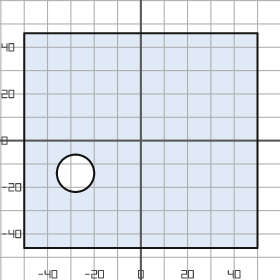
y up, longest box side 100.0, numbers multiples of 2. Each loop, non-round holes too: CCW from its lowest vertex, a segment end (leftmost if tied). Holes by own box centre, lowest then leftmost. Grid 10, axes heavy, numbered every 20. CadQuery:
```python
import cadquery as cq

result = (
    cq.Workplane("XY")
    .moveTo(-50.0, -46.0)
    .lineTo(50.0, -46.0)
    .lineTo(50.0, 46.0)
    .lineTo(-50.0, 46.0)
    .close()
    .moveTo(-28.0, -14.0)
    .circle(8.0)
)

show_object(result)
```